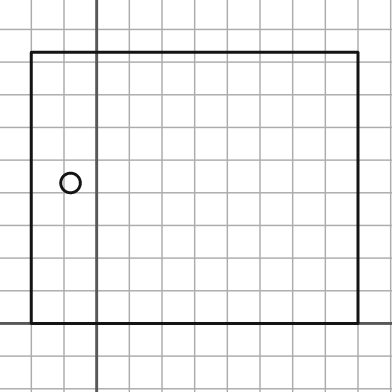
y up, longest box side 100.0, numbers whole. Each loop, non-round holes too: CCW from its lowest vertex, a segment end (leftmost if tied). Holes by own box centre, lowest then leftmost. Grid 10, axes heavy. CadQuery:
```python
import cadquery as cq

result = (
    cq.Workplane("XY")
    .moveTo(-20.0, 0.0)
    .lineTo(80.0, 0.0)
    .lineTo(80.0, 83.0)
    .lineTo(-20.0, 83.0)
    .close()
    .moveTo(-8.0, 43.0)
    .circle(3.0)
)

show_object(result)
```